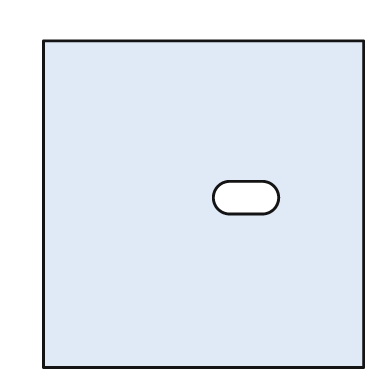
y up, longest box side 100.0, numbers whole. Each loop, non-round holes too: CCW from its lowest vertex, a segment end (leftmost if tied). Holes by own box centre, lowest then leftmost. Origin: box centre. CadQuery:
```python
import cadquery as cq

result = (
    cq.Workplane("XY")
    .moveTo(-49.0, -50.0)
    .lineTo(49.0, -50.0)
    .lineTo(49.0, 50.0)
    .lineTo(-49.0, 50.0)
    .close()
    .moveTo(8.0, -3.0)
    .lineTo(18.0, -3.0)
    .threePointArc((23.0, 2.0), (18.0, 7.0))
    .lineTo(8.0, 7.0)
    .threePointArc((3.0, 2.0), (8.0, -3.0))
    .close()
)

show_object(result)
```